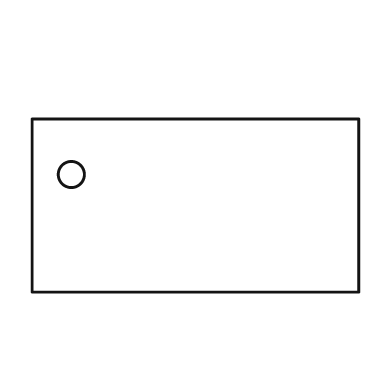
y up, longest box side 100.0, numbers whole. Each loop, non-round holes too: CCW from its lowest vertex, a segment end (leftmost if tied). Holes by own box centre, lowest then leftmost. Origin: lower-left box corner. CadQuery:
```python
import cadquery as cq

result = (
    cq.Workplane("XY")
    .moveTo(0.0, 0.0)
    .lineTo(100.0, 0.0)
    .lineTo(100.0, 53.0)
    .lineTo(0.0, 53.0)
    .close()
    .moveTo(12.0, 36.0)
    .circle(4.0)
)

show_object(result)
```